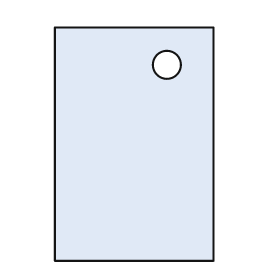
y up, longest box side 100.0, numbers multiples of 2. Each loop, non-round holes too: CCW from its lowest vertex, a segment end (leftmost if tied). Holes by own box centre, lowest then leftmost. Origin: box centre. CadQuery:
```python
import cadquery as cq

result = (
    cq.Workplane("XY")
    .moveTo(-34.0, -50.0)
    .lineTo(34.0, -50.0)
    .lineTo(34.0, 50.0)
    .lineTo(-34.0, 50.0)
    .close()
    .moveTo(14.0, 34.0)
    .circle(6.0)
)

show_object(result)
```